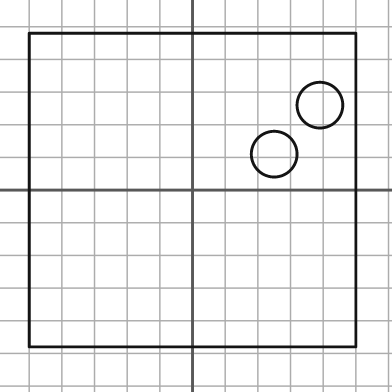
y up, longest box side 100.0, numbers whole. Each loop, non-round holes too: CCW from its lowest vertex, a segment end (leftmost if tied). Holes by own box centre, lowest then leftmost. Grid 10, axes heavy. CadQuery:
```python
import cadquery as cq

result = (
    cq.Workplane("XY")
    .moveTo(-50.0, -48.0)
    .lineTo(50.0, -48.0)
    .lineTo(50.0, 48.0)
    .lineTo(-50.0, 48.0)
    .close()
    .moveTo(25.0, 11.0)
    .circle(7.0)
    .moveTo(39.0, 26.0)
    .circle(7.0)
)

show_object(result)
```